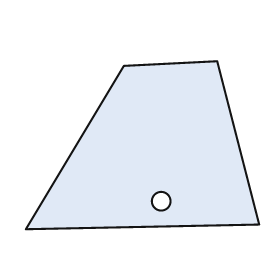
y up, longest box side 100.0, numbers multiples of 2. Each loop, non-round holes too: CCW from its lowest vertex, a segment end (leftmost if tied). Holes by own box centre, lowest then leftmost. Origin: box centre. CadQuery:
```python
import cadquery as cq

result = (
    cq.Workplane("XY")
    .moveTo(-50.0, -36.0)
    .lineTo(50.0, -34.0)
    .lineTo(32.0, 36.0)
    .lineTo(-8.0, 34.0)
    .close()
    .moveTo(8.0, -24.0)
    .circle(4.0)
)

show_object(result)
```